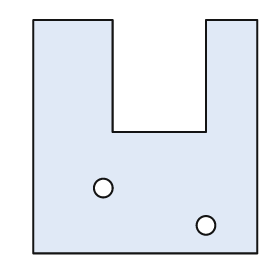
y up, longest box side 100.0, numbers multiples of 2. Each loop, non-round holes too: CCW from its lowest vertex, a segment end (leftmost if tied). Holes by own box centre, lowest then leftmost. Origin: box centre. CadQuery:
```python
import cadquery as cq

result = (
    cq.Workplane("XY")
    .moveTo(-48.0, -50.0)
    .lineTo(48.0, -50.0)
    .lineTo(48.0, 50.0)
    .lineTo(26.0, 50.0)
    .lineTo(26.0, 2.0)
    .lineTo(-14.0, 2.0)
    .lineTo(-14.0, 50.0)
    .lineTo(-48.0, 50.0)
    .close()
    .moveTo(26.0, -38.0)
    .circle(4.0)
    .moveTo(-18.0, -22.0)
    .circle(4.0)
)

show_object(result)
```